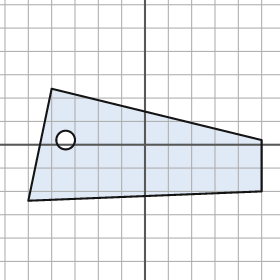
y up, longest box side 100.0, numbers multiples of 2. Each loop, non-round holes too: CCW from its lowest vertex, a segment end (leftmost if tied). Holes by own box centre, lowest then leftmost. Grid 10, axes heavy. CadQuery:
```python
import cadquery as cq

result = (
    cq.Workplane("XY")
    .moveTo(-50.0, -24.0)
    .lineTo(50.0, -20.0)
    .lineTo(50.0, 2.0)
    .lineTo(-40.0, 24.0)
    .close()
    .moveTo(-34.0, 2.0)
    .circle(4.0)
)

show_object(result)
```